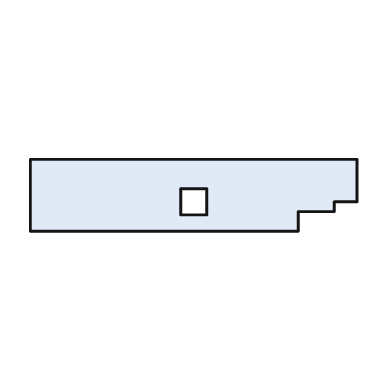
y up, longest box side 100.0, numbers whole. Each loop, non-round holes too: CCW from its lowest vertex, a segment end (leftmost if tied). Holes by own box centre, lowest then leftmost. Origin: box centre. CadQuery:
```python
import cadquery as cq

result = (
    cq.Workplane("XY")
    .moveTo(-50.0, -11.0)
    .lineTo(32.0, -11.0)
    .lineTo(32.0, -5.0)
    .lineTo(43.0, -5.0)
    .lineTo(43.0, -2.0)
    .lineTo(50.0, -2.0)
    .lineTo(50.0, 11.0)
    .lineTo(-50.0, 11.0)
    .close()
    .moveTo(-4.0, -6.0)
    .lineTo(4.0, -6.0)
    .lineTo(4.0, 2.0)
    .lineTo(-4.0, 2.0)
    .close()
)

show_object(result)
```